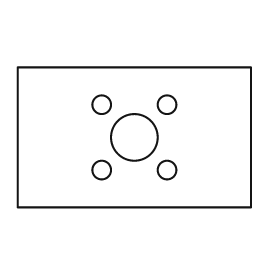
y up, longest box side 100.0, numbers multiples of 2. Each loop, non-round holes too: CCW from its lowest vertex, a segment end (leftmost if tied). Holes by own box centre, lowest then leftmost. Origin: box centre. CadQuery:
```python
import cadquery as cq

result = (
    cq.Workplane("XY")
    .moveTo(-50.0, -30.0)
    .lineTo(50.0, -30.0)
    .lineTo(50.0, 30.0)
    .lineTo(-50.0, 30.0)
    .close()
    .moveTo(-14.0, -14.0)
    .circle(4.0)
    .moveTo(14.0, -14.0)
    .circle(4.0)
    .moveTo(0.0, 0.0)
    .circle(10.0)
    .moveTo(-14.0, 14.0)
    .circle(4.0)
    .moveTo(14.0, 14.0)
    .circle(4.0)
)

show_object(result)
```